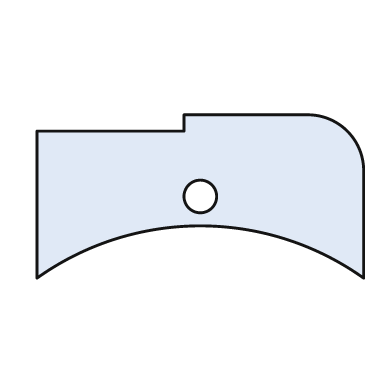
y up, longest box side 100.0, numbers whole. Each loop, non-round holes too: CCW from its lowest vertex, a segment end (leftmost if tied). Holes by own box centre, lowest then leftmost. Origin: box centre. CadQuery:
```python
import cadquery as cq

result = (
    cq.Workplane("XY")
    .moveTo(-50.0, -25.0)
    .threePointArc((0.0, -9.0), (50.0, -25.0))
    .lineTo(50.0, 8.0)
    .threePointArc((45.0, 20.0), (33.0, 25.0))
    .lineTo(-5.0, 25.0)
    .lineTo(-5.0, 20.0)
    .lineTo(-50.0, 20.0)
    .close()
    .moveTo(0.0, 0.0)
    .circle(5.0)
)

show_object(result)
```